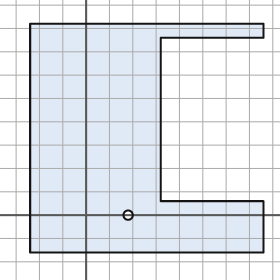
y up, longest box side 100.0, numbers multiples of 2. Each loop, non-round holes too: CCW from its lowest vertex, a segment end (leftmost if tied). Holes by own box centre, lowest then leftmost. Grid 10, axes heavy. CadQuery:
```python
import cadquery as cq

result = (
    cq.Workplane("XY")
    .moveTo(-24.0, -16.0)
    .lineTo(76.0, -16.0)
    .lineTo(76.0, 6.0)
    .lineTo(32.0, 6.0)
    .lineTo(32.0, 76.0)
    .lineTo(76.0, 76.0)
    .lineTo(76.0, 82.0)
    .lineTo(-24.0, 82.0)
    .close()
    .moveTo(18.0, 0.0)
    .circle(2.0)
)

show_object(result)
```